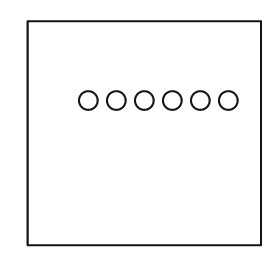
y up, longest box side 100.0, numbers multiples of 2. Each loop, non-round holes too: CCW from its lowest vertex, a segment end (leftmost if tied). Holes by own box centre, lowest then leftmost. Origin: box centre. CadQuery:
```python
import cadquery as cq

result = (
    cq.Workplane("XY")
    .moveTo(-50.0, -48.0)
    .lineTo(50.0, -48.0)
    .lineTo(50.0, 48.0)
    .lineTo(-50.0, 48.0)
    .close()
    .moveTo(-24.0, 14.0)
    .circle(4.0)
    .moveTo(-12.0, 14.0)
    .circle(4.0)
    .moveTo(0.0, 14.0)
    .circle(4.0)
    .moveTo(12.0, 14.0)
    .circle(4.0)
    .moveTo(24.0, 14.0)
    .circle(4.0)
    .moveTo(36.0, 14.0)
    .circle(4.0)
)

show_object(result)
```